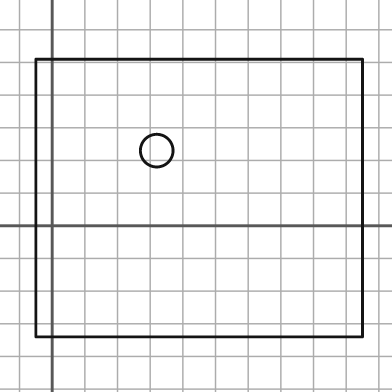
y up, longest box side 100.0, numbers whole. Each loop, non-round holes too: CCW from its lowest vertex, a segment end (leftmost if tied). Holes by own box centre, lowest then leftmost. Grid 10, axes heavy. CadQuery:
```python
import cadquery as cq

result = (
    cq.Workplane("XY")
    .moveTo(-5.0, -34.0)
    .lineTo(95.0, -34.0)
    .lineTo(95.0, 51.0)
    .lineTo(-5.0, 51.0)
    .close()
    .moveTo(32.0, 23.0)
    .circle(5.0)
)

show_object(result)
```